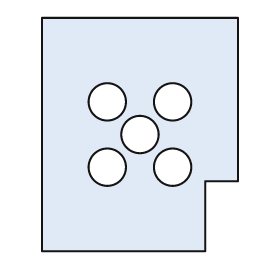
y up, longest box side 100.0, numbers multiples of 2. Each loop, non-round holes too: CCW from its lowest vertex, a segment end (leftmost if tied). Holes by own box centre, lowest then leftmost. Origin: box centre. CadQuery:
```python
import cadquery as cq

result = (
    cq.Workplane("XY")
    .moveTo(-42.0, -50.0)
    .lineTo(28.0, -50.0)
    .lineTo(28.0, -20.0)
    .lineTo(42.0, -20.0)
    .lineTo(42.0, 50.0)
    .lineTo(-42.0, 50.0)
    .close()
    .moveTo(-14.0, -14.0)
    .circle(8.0)
    .moveTo(14.0, -14.0)
    .circle(8.0)
    .moveTo(0.0, 0.0)
    .circle(8.0)
    .moveTo(-14.0, 14.0)
    .circle(8.0)
    .moveTo(14.0, 14.0)
    .circle(8.0)
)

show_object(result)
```